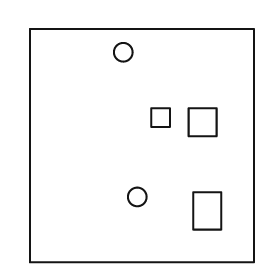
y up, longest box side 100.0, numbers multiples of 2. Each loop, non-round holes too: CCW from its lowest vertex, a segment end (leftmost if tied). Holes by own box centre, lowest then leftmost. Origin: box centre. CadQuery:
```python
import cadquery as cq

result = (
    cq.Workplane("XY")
    .moveTo(-48.0, -50.0)
    .lineTo(48.0, -50.0)
    .lineTo(48.0, 50.0)
    .lineTo(-48.0, 50.0)
    .close()
    .moveTo(22.0, -36.0)
    .lineTo(34.0, -36.0)
    .lineTo(34.0, -20.0)
    .lineTo(22.0, -20.0)
    .close()
    .moveTo(-2.0, -22.0)
    .circle(4.0)
    .moveTo(20.0, 4.0)
    .lineTo(32.0, 4.0)
    .lineTo(32.0, 16.0)
    .lineTo(20.0, 16.0)
    .close()
    .moveTo(4.0, 8.0)
    .lineTo(12.0, 8.0)
    .lineTo(12.0, 16.0)
    .lineTo(4.0, 16.0)
    .close()
    .moveTo(-8.0, 40.0)
    .circle(4.0)
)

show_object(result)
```